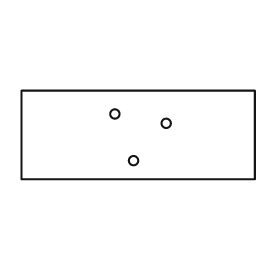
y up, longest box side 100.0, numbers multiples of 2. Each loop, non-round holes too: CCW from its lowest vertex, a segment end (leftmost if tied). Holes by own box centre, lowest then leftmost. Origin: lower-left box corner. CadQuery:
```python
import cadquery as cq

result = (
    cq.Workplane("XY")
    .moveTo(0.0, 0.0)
    .lineTo(100.0, 0.0)
    .lineTo(100.0, 38.0)
    .lineTo(0.0, 38.0)
    .close()
    .moveTo(48.0, 8.0)
    .circle(2.0)
    .moveTo(62.0, 24.0)
    .circle(2.0)
    .moveTo(40.0, 28.0)
    .circle(2.0)
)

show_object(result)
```